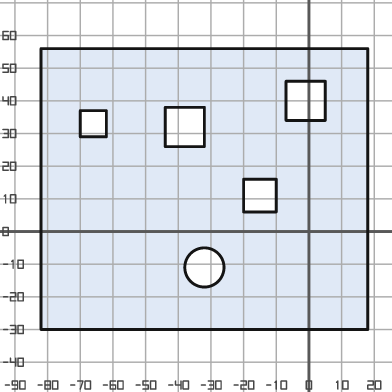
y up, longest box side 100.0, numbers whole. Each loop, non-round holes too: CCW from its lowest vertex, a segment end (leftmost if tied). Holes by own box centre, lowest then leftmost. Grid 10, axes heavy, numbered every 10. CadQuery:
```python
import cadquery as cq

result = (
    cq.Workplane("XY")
    .moveTo(-82.0, -30.0)
    .lineTo(18.0, -30.0)
    .lineTo(18.0, 56.0)
    .lineTo(-82.0, 56.0)
    .close()
    .moveTo(-32.0, -11.0)
    .circle(6.0)
    .moveTo(-20.0, 6.0)
    .lineTo(-10.0, 6.0)
    .lineTo(-10.0, 16.0)
    .lineTo(-20.0, 16.0)
    .close()
    .moveTo(-44.0, 26.0)
    .lineTo(-32.0, 26.0)
    .lineTo(-32.0, 38.0)
    .lineTo(-44.0, 38.0)
    .close()
    .moveTo(-70.0, 29.0)
    .lineTo(-62.0, 29.0)
    .lineTo(-62.0, 37.0)
    .lineTo(-70.0, 37.0)
    .close()
    .moveTo(-7.0, 34.0)
    .lineTo(5.0, 34.0)
    .lineTo(5.0, 46.0)
    .lineTo(-7.0, 46.0)
    .close()
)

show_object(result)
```